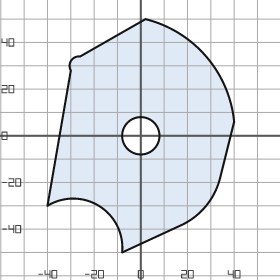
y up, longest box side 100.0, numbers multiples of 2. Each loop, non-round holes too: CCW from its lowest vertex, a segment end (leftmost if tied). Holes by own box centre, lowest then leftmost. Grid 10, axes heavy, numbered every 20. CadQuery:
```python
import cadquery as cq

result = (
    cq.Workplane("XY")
    .moveTo(-8.0, -50.0)
    .lineTo(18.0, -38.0)
    .threePointArc((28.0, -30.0), (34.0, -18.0))
    .lineTo(40.0, 6.0)
    .threePointArc((28.0, 34.0), (2.0, 50.0))
    .lineTo(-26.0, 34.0)
    .threePointArc((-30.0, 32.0), (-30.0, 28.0))
    .lineTo(-40.0, -30.0)
    .threePointArc((-18.0, -30.0), (-8.0, -50.0))
    .close()
    .moveTo(0.0, 0.0)
    .circle(8.0)
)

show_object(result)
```